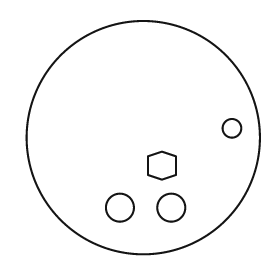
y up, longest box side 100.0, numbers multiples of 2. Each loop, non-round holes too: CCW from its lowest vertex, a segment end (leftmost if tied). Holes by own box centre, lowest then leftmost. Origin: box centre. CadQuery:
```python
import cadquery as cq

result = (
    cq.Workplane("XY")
    .moveTo(0.0, 0.0)
    .circle(50.0)
    .moveTo(-10.0, -30.0)
    .circle(6.0)
    .moveTo(12.0, -30.0)
    .circle(6.0)
    .moveTo(8.0, -18.0)
    .lineTo(14.0, -16.0)
    .lineTo(14.0, -8.0)
    .lineTo(8.0, -6.0)
    .lineTo(2.0, -8.0)
    .lineTo(2.0, -16.0)
    .close()
    .moveTo(38.0, 4.0)
    .circle(4.0)
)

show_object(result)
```